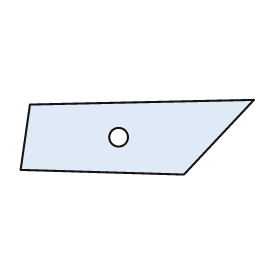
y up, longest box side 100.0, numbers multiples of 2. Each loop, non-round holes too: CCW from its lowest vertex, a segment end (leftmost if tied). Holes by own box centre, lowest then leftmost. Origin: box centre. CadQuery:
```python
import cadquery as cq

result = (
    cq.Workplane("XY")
    .moveTo(20.0, -16.0)
    .lineTo(50.0, 16.0)
    .lineTo(-46.0, 14.0)
    .lineTo(-50.0, -14.0)
    .close()
    .moveTo(-8.0, 0.0)
    .circle(4.0)
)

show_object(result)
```